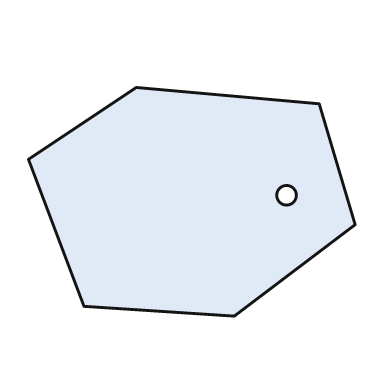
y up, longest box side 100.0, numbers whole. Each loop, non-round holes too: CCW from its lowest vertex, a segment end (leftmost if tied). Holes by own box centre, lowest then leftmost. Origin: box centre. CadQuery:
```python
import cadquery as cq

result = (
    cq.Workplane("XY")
    .moveTo(13.0, -35.0)
    .lineTo(50.0, -7.0)
    .lineTo(39.0, 30.0)
    .lineTo(-17.0, 35.0)
    .lineTo(-50.0, 13.0)
    .lineTo(-33.0, -32.0)
    .close()
    .moveTo(29.0, 2.0)
    .circle(3.0)
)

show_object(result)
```